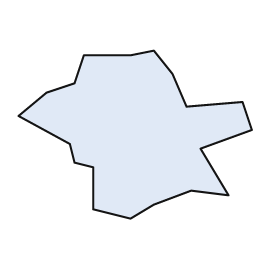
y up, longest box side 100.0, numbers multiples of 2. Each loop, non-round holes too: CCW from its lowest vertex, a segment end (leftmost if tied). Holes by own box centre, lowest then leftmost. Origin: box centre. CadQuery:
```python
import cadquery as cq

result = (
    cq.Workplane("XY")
    .moveTo(-2.0, -36.0)
    .lineTo(8.0, -30.0)
    .lineTo(24.0, -24.0)
    .lineTo(40.0, -26.0)
    .lineTo(28.0, -6.0)
    .lineTo(50.0, 2.0)
    .lineTo(46.0, 14.0)
    .lineTo(22.0, 12.0)
    .lineTo(16.0, 26.0)
    .lineTo(8.0, 36.0)
    .lineTo(-2.0, 34.0)
    .lineTo(-22.0, 34.0)
    .lineTo(-26.0, 22.0)
    .lineTo(-38.0, 18.0)
    .lineTo(-50.0, 8.0)
    .lineTo(-28.0, -4.0)
    .lineTo(-26.0, -12.0)
    .lineTo(-18.0, -14.0)
    .lineTo(-18.0, -32.0)
    .close()
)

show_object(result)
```